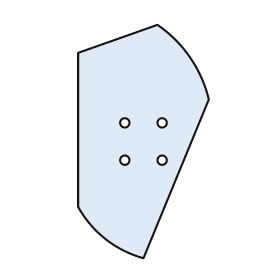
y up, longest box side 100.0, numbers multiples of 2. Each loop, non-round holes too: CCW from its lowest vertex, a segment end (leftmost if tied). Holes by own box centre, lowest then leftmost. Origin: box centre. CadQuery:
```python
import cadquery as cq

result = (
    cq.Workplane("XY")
    .moveTo(0.0, -50.0)
    .lineTo(28.0, 18.0)
    .threePointArc((20.0, 36.0), (6.0, 50.0))
    .lineTo(-28.0, 38.0)
    .lineTo(-28.0, -28.0)
    .threePointArc((-16.0, -42.0), (0.0, -50.0))
    .close()
    .moveTo(-8.0, -8.0)
    .circle(2.0)
    .moveTo(8.0, -8.0)
    .circle(2.0)
    .moveTo(-8.0, 8.0)
    .circle(2.0)
    .moveTo(8.0, 8.0)
    .circle(2.0)
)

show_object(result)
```